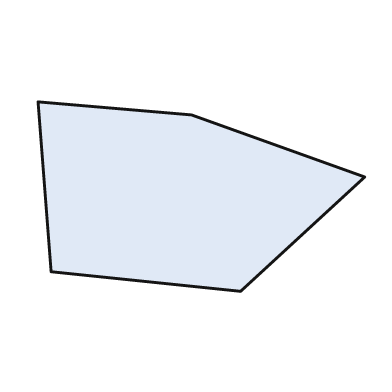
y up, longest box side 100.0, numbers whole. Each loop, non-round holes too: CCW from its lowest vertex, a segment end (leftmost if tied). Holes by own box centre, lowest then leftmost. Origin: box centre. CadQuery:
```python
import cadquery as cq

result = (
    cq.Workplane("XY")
    .moveTo(12.0, -29.0)
    .lineTo(50.0, 6.0)
    .lineTo(-3.0, 25.0)
    .lineTo(-50.0, 29.0)
    .lineTo(-46.0, -23.0)
    .close()
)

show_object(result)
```